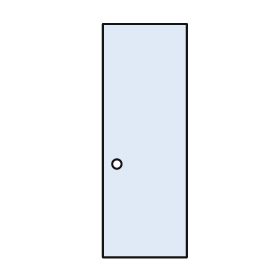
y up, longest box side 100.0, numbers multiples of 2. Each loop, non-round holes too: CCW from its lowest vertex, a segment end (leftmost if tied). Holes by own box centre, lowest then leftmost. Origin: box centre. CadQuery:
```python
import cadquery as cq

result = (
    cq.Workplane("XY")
    .moveTo(-18.0, -50.0)
    .lineTo(18.0, -50.0)
    .lineTo(18.0, 50.0)
    .lineTo(-18.0, 50.0)
    .close()
    .moveTo(-12.0, -10.0)
    .circle(2.0)
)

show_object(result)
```